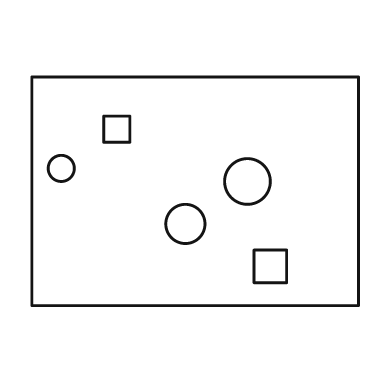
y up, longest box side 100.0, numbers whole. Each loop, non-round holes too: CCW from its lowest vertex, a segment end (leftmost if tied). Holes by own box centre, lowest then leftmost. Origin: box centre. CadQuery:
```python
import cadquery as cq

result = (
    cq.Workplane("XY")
    .moveTo(-50.0, -35.0)
    .lineTo(50.0, -35.0)
    .lineTo(50.0, 35.0)
    .lineTo(-50.0, 35.0)
    .close()
    .moveTo(18.0, -28.0)
    .lineTo(28.0, -28.0)
    .lineTo(28.0, -18.0)
    .lineTo(18.0, -18.0)
    .close()
    .moveTo(-3.0, -10.0)
    .circle(6.0)
    .moveTo(16.0, 3.0)
    .circle(7.0)
    .moveTo(-41.0, 7.0)
    .circle(4.0)
    .moveTo(-28.0, 15.0)
    .lineTo(-20.0, 15.0)
    .lineTo(-20.0, 23.0)
    .lineTo(-28.0, 23.0)
    .close()
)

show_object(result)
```